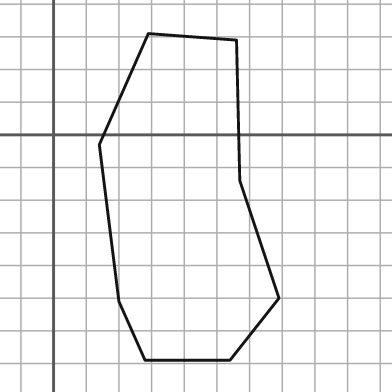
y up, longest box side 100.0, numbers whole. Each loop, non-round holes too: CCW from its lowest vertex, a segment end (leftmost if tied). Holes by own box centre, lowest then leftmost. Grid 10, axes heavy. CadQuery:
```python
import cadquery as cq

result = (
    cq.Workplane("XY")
    .moveTo(28.0, -69.0)
    .lineTo(54.0, -69.0)
    .lineTo(69.0, -50.0)
    .lineTo(57.0, -14.0)
    .lineTo(56.0, 29.0)
    .lineTo(29.0, 31.0)
    .lineTo(14.0, -3.0)
    .lineTo(20.0, -51.0)
    .close()
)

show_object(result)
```